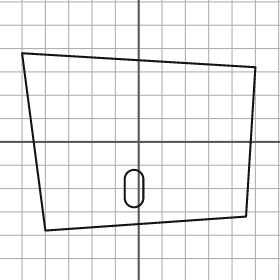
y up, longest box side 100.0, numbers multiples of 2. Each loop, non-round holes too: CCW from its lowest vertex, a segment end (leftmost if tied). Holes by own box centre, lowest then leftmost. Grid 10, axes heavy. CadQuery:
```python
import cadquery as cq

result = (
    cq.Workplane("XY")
    .moveTo(-40.0, -38.0)
    .lineTo(46.0, -32.0)
    .lineTo(50.0, 32.0)
    .lineTo(-50.0, 38.0)
    .close()
    .moveTo(-6.0, -24.0)
    .threePointArc((-2.0, -28.0), (2.0, -24.0))
    .lineTo(2.0, -16.0)
    .threePointArc((-2.0, -12.0), (-6.0, -16.0))
    .close()
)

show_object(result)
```